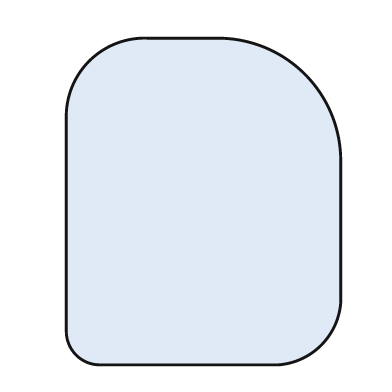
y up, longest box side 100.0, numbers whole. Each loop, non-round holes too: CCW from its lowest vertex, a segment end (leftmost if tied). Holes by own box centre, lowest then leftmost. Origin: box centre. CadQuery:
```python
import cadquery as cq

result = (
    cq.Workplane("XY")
    .moveTo(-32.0, -50.0)
    .lineTo(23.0, -50.0)
    .threePointArc((36.0, -44.0), (42.0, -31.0))
    .lineTo(42.0, 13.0)
    .threePointArc((31.0, 39.0), (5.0, 50.0))
    .lineTo(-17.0, 50.0)
    .threePointArc((-35.0, 43.0), (-42.0, 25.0))
    .lineTo(-42.0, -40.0)
    .threePointArc((-39.0, -47.0), (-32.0, -50.0))
    .close()
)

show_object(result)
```